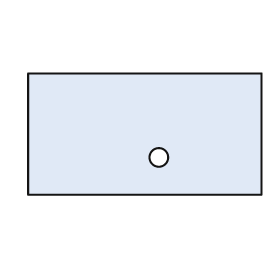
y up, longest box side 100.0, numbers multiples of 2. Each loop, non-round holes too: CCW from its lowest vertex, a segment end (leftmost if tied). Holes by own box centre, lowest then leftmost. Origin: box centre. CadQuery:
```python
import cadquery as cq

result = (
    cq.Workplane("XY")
    .moveTo(-50.0, -26.0)
    .lineTo(50.0, -26.0)
    .lineTo(50.0, 26.0)
    .lineTo(-50.0, 26.0)
    .close()
    .moveTo(6.0, -10.0)
    .circle(4.0)
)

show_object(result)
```